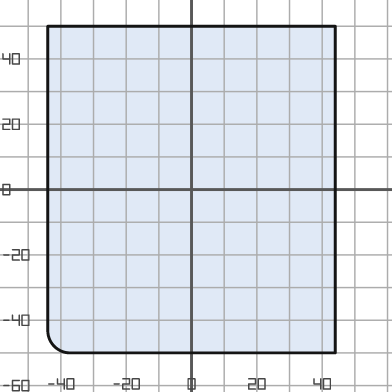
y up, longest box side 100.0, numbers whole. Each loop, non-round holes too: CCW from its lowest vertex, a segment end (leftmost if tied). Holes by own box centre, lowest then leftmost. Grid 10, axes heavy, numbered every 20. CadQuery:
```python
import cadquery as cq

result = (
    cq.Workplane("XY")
    .moveTo(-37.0, -50.0)
    .lineTo(44.0, -50.0)
    .lineTo(44.0, 50.0)
    .lineTo(-44.0, 50.0)
    .lineTo(-44.0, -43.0)
    .threePointArc((-42.0, -48.0), (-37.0, -50.0))
    .close()
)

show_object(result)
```